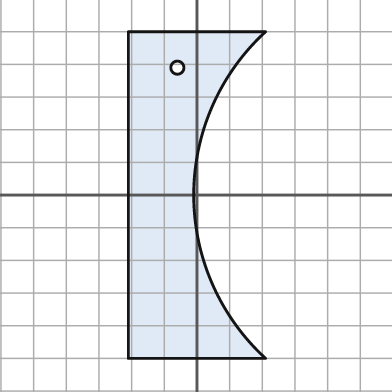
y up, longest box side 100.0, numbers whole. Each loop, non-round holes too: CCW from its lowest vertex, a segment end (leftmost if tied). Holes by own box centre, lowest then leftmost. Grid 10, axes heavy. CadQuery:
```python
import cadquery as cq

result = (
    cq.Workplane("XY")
    .moveTo(-21.0, -50.0)
    .lineTo(21.0, -50.0)
    .threePointArc((-1.0, 0.0), (21.0, 50.0))
    .lineTo(-21.0, 50.0)
    .close()
    .moveTo(-6.0, 39.0)
    .circle(2.0)
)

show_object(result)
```